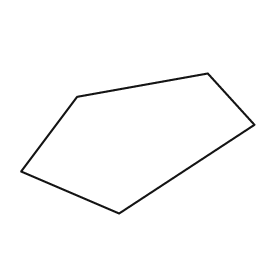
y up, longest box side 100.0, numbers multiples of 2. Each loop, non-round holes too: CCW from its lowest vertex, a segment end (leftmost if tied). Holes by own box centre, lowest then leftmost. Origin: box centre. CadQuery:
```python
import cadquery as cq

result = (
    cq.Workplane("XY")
    .moveTo(-8.0, -30.0)
    .lineTo(50.0, 8.0)
    .lineTo(30.0, 30.0)
    .lineTo(-26.0, 20.0)
    .lineTo(-50.0, -12.0)
    .close()
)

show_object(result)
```